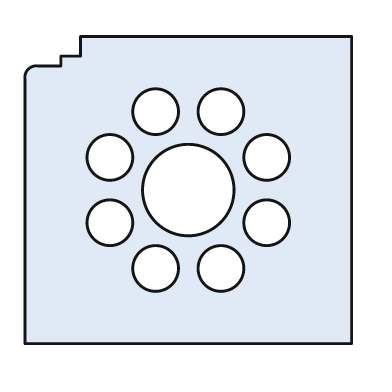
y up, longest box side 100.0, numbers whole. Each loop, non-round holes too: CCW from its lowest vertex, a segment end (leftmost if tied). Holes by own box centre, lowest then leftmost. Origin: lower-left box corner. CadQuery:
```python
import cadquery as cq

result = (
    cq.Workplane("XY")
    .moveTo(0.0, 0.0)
    .lineTo(100.0, 0.0)
    .lineTo(100.0, 94.0)
    .lineTo(17.0, 94.0)
    .lineTo(17.0, 88.0)
    .lineTo(11.0, 88.0)
    .lineTo(11.0, 85.0)
    .lineTo(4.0, 85.0)
    .threePointArc((1.0, 84.0), (0.0, 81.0))
    .close()
    .moveTo(40.0, 23.0)
    .circle(7.0)
    .moveTo(60.0, 23.0)
    .circle(7.0)
    .moveTo(26.0, 37.0)
    .circle(7.0)
    .moveTo(74.0, 37.0)
    .circle(7.0)
    .moveTo(50.0, 47.0)
    .circle(14.0)
    .moveTo(26.0, 57.0)
    .circle(7.0)
    .moveTo(74.0, 57.0)
    .circle(7.0)
    .moveTo(40.0, 71.0)
    .circle(7.0)
    .moveTo(60.0, 71.0)
    .circle(7.0)
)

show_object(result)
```